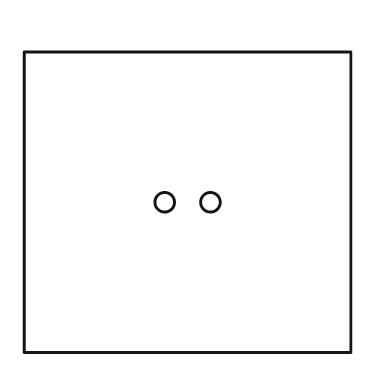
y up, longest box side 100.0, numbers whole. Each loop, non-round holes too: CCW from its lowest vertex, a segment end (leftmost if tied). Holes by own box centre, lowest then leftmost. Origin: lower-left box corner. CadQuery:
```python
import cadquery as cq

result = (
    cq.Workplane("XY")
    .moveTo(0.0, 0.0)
    .lineTo(100.0, 0.0)
    .lineTo(100.0, 92.0)
    .lineTo(0.0, 92.0)
    .close()
    .moveTo(43.0, 46.0)
    .circle(3.0)
    .moveTo(57.0, 46.0)
    .circle(3.0)
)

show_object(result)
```